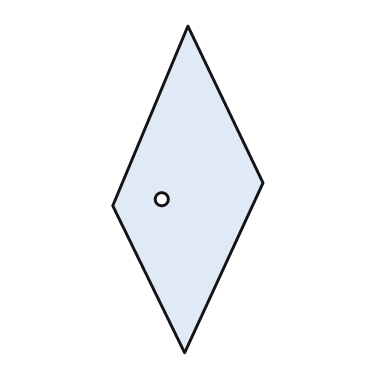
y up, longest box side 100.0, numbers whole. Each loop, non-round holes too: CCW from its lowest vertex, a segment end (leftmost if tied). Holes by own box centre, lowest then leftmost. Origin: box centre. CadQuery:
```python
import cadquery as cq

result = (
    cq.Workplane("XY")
    .moveTo(-1.0, -50.0)
    .lineTo(23.0, 2.0)
    .lineTo(0.0, 50.0)
    .lineTo(-23.0, -5.0)
    .close()
    .moveTo(-8.0, -3.0)
    .circle(2.0)
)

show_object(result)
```